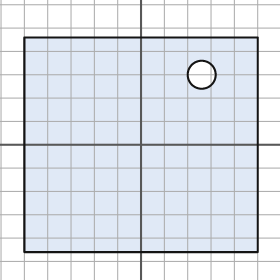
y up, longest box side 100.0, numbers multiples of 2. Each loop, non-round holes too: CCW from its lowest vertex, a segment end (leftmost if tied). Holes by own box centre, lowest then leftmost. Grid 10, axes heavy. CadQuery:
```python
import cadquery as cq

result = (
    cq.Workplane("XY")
    .moveTo(-50.0, -46.0)
    .lineTo(50.0, -46.0)
    .lineTo(50.0, 46.0)
    .lineTo(-50.0, 46.0)
    .close()
    .moveTo(26.0, 30.0)
    .circle(6.0)
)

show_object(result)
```